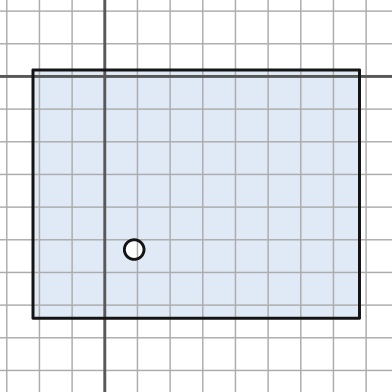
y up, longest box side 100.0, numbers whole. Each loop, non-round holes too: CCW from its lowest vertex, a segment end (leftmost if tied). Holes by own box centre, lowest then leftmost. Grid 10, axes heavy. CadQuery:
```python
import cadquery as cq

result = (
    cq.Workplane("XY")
    .moveTo(-22.0, -74.0)
    .lineTo(78.0, -74.0)
    .lineTo(78.0, 2.0)
    .lineTo(-22.0, 2.0)
    .close()
    .moveTo(9.0, -53.0)
    .circle(3.0)
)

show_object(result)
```